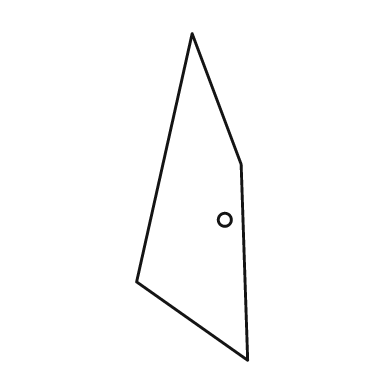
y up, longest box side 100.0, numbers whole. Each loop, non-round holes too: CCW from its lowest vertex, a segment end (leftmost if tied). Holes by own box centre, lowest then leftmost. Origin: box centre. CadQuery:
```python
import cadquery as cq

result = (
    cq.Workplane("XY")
    .moveTo(17.0, -50.0)
    .lineTo(15.0, 10.0)
    .lineTo(0.0, 50.0)
    .lineTo(-17.0, -26.0)
    .close()
    .moveTo(10.0, -7.0)
    .circle(2.0)
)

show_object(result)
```